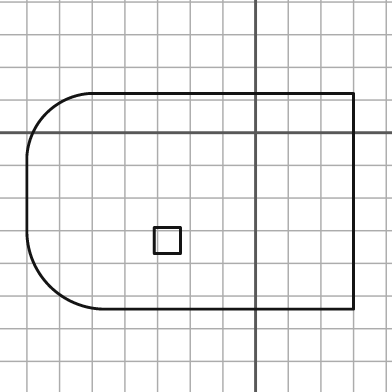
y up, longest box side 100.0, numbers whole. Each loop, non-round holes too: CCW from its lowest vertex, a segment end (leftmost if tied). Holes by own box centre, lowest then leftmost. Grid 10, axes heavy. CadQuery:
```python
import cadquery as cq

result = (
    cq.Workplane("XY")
    .moveTo(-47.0, -54.0)
    .lineTo(30.0, -54.0)
    .lineTo(30.0, 12.0)
    .lineTo(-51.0, 12.0)
    .threePointArc((-64.0, 6.0), (-70.0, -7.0))
    .lineTo(-70.0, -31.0)
    .threePointArc((-63.0, -47.0), (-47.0, -54.0))
    .close()
    .moveTo(-31.0, -37.0)
    .lineTo(-23.0, -37.0)
    .lineTo(-23.0, -29.0)
    .lineTo(-31.0, -29.0)
    .close()
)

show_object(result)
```